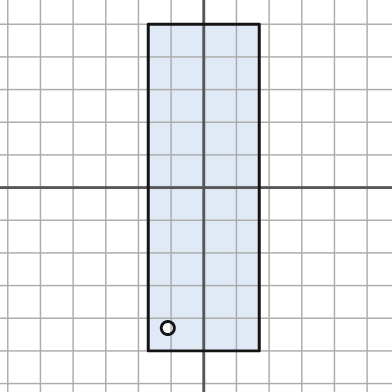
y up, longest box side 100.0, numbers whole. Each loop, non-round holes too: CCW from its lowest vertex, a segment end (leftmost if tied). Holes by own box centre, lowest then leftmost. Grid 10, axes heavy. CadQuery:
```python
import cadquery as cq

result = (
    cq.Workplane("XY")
    .moveTo(-17.0, -50.0)
    .lineTo(17.0, -50.0)
    .lineTo(17.0, 50.0)
    .lineTo(-17.0, 50.0)
    .close()
    .moveTo(-11.0, -43.0)
    .circle(2.0)
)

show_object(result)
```